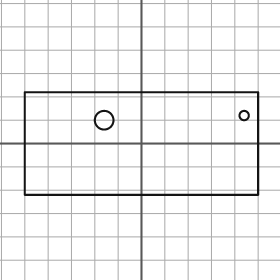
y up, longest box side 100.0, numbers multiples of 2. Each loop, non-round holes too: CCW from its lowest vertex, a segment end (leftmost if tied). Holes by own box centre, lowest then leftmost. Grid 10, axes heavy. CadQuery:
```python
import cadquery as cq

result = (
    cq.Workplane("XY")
    .moveTo(-50.0, -22.0)
    .lineTo(50.0, -22.0)
    .lineTo(50.0, 22.0)
    .lineTo(-50.0, 22.0)
    .close()
    .moveTo(-16.0, 10.0)
    .circle(4.0)
    .moveTo(44.0, 12.0)
    .circle(2.0)
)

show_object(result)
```